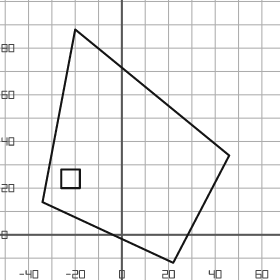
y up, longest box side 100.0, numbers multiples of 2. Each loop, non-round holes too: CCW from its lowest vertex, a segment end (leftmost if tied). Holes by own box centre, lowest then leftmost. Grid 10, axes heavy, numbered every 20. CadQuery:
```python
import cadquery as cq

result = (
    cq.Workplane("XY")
    .moveTo(22.0, -12.0)
    .lineTo(46.0, 34.0)
    .lineTo(-20.0, 88.0)
    .lineTo(-34.0, 14.0)
    .close()
    .moveTo(-26.0, 20.0)
    .lineTo(-18.0, 20.0)
    .lineTo(-18.0, 28.0)
    .lineTo(-26.0, 28.0)
    .close()
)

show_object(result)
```